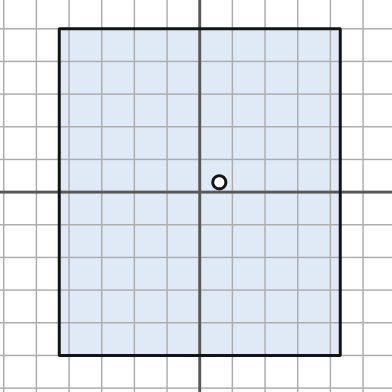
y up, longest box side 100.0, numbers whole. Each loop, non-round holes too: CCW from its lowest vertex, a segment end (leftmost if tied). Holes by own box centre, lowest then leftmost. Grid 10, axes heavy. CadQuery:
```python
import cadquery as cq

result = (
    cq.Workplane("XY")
    .moveTo(-43.0, -50.0)
    .lineTo(43.0, -50.0)
    .lineTo(43.0, 50.0)
    .lineTo(-43.0, 50.0)
    .close()
    .moveTo(6.0, 3.0)
    .circle(2.0)
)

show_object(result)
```